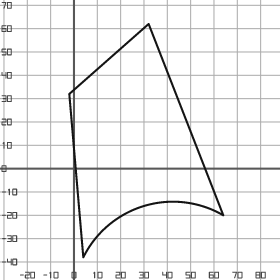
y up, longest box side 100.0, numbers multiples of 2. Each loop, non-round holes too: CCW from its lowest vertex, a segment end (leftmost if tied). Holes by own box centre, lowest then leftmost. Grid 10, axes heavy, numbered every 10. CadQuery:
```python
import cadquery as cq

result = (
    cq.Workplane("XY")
    .moveTo(4.0, -38.0)
    .threePointArc((30.0, -16.0), (64.0, -20.0))
    .lineTo(32.0, 62.0)
    .lineTo(-2.0, 32.0)
    .close()
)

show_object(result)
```